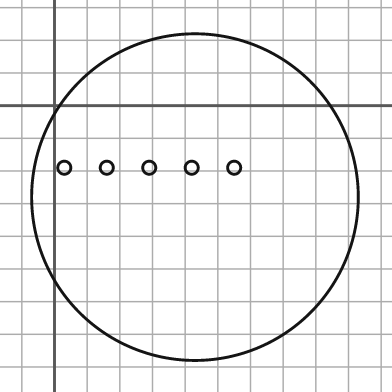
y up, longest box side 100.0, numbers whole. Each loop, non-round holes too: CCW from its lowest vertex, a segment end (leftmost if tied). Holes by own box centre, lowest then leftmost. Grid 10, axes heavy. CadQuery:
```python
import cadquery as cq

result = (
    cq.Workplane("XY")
    .moveTo(43.0, -28.0)
    .circle(50.0)
    .moveTo(3.0, -19.0)
    .circle(2.0)
    .moveTo(16.0, -19.0)
    .circle(2.0)
    .moveTo(29.0, -19.0)
    .circle(2.0)
    .moveTo(42.0, -19.0)
    .circle(2.0)
    .moveTo(55.0, -19.0)
    .circle(2.0)
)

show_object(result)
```